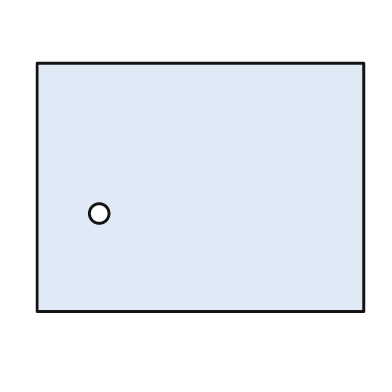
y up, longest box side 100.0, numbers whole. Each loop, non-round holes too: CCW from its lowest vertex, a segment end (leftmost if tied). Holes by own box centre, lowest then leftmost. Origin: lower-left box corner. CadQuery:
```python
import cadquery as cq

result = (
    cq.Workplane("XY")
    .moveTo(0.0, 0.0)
    .lineTo(100.0, 0.0)
    .lineTo(100.0, 76.0)
    .lineTo(0.0, 76.0)
    .close()
    .moveTo(19.0, 30.0)
    .circle(3.0)
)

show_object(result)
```